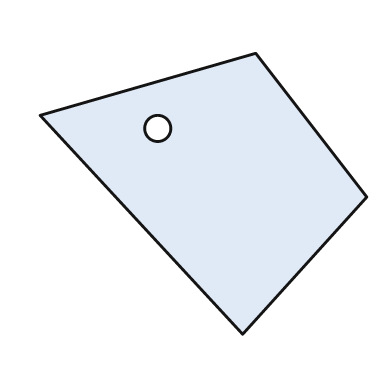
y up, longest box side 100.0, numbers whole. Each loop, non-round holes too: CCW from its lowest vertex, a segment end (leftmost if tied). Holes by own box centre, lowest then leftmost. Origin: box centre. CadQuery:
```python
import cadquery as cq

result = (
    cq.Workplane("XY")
    .moveTo(12.0, -43.0)
    .lineTo(50.0, -1.0)
    .lineTo(16.0, 43.0)
    .lineTo(-50.0, 24.0)
    .close()
    .moveTo(-14.0, 20.0)
    .circle(4.0)
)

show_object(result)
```